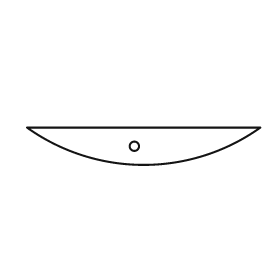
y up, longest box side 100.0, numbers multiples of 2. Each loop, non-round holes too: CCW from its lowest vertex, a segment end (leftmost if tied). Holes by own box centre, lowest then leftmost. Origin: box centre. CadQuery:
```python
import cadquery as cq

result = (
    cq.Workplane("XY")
    .moveTo(-50.0, 8.0)
    .threePointArc((0.0, -8.0), (50.0, 8.0))
    .close()
    .moveTo(-4.0, 0.0)
    .circle(2.0)
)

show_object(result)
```